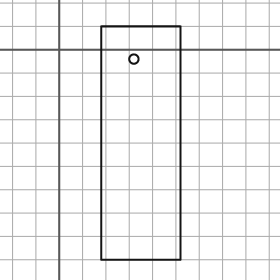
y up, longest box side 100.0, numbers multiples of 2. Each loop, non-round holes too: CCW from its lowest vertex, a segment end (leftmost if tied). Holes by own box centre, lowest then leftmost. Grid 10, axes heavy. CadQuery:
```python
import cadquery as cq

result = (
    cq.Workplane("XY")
    .moveTo(18.0, -90.0)
    .lineTo(52.0, -90.0)
    .lineTo(52.0, 10.0)
    .lineTo(18.0, 10.0)
    .close()
    .moveTo(32.0, -4.0)
    .circle(2.0)
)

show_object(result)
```